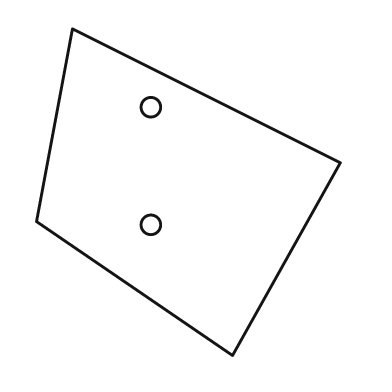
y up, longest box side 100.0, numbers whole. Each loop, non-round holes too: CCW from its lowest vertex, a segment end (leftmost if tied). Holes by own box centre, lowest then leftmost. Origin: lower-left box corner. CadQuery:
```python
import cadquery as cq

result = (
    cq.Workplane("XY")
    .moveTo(60.0, 0.0)
    .lineTo(93.0, 59.0)
    .lineTo(11.0, 100.0)
    .lineTo(0.0, 41.0)
    .close()
    .moveTo(35.0, 40.0)
    .circle(3.0)
    .moveTo(35.0, 76.0)
    .circle(3.0)
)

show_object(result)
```